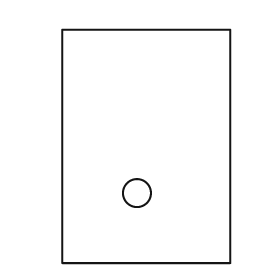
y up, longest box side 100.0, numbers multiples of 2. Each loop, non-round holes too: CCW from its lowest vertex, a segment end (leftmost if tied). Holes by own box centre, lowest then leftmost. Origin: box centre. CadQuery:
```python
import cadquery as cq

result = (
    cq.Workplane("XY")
    .moveTo(-36.0, -50.0)
    .lineTo(36.0, -50.0)
    .lineTo(36.0, 50.0)
    .lineTo(-36.0, 50.0)
    .close()
    .moveTo(-4.0, -20.0)
    .circle(6.0)
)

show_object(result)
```